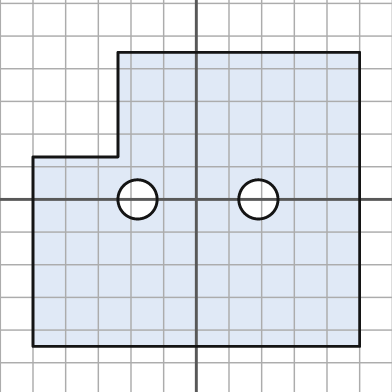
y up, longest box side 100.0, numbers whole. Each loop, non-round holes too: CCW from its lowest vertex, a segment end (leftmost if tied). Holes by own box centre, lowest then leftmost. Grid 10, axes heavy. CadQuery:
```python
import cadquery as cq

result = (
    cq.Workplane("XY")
    .moveTo(-50.0, -45.0)
    .lineTo(50.0, -45.0)
    .lineTo(50.0, 45.0)
    .lineTo(-24.0, 45.0)
    .lineTo(-24.0, 13.0)
    .lineTo(-50.0, 13.0)
    .close()
    .moveTo(-18.0, 0.0)
    .circle(6.0)
    .moveTo(19.0, 0.0)
    .circle(6.0)
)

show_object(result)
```